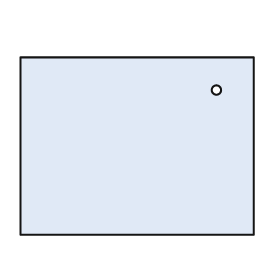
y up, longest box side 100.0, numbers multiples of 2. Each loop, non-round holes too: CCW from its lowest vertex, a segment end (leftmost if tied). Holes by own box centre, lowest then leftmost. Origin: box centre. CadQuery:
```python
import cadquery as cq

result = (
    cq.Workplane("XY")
    .moveTo(-50.0, -38.0)
    .lineTo(50.0, -38.0)
    .lineTo(50.0, 38.0)
    .lineTo(-50.0, 38.0)
    .close()
    .moveTo(34.0, 24.0)
    .circle(2.0)
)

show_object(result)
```